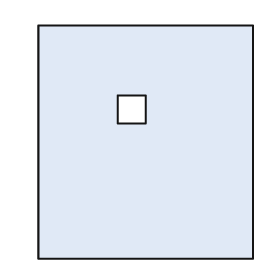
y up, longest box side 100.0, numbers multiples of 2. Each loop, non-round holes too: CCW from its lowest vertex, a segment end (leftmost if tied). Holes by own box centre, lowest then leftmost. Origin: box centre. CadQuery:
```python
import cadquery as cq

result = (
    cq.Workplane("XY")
    .moveTo(-46.0, -50.0)
    .lineTo(46.0, -50.0)
    .lineTo(46.0, 50.0)
    .lineTo(-46.0, 50.0)
    .close()
    .moveTo(-12.0, 8.0)
    .lineTo(0.0, 8.0)
    .lineTo(0.0, 20.0)
    .lineTo(-12.0, 20.0)
    .close()
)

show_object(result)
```